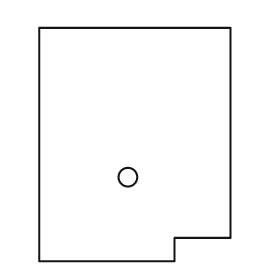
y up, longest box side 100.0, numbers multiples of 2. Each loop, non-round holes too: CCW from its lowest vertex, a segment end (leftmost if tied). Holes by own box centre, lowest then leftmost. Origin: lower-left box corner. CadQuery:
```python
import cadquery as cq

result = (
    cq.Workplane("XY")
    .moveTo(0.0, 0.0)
    .lineTo(58.0, 0.0)
    .lineTo(58.0, 10.0)
    .lineTo(82.0, 10.0)
    .lineTo(82.0, 100.0)
    .lineTo(0.0, 100.0)
    .close()
    .moveTo(38.0, 36.0)
    .circle(4.0)
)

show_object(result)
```